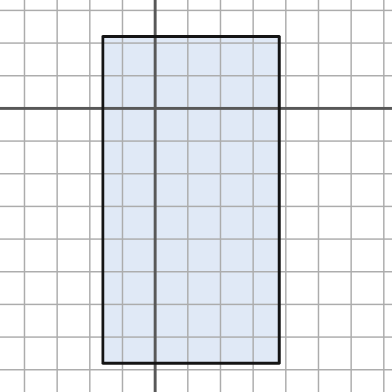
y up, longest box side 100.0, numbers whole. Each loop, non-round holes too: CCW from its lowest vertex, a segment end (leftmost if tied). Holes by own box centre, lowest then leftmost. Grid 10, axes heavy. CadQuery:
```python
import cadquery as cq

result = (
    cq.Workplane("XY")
    .moveTo(-16.0, -78.0)
    .lineTo(38.0, -78.0)
    .lineTo(38.0, 22.0)
    .lineTo(-16.0, 22.0)
    .close()
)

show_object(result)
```